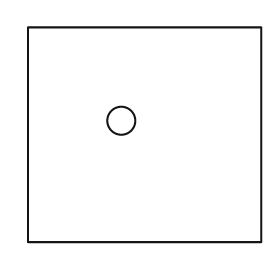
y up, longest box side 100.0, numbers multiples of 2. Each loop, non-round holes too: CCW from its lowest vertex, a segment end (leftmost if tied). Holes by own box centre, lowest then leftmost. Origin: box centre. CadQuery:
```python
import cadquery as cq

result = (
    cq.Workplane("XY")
    .moveTo(-50.0, -46.0)
    .lineTo(50.0, -46.0)
    .lineTo(50.0, 46.0)
    .lineTo(-50.0, 46.0)
    .close()
    .moveTo(-10.0, 6.0)
    .circle(6.0)
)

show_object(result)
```